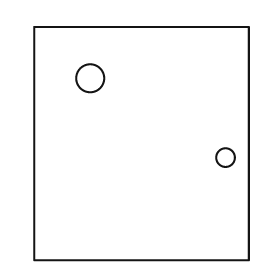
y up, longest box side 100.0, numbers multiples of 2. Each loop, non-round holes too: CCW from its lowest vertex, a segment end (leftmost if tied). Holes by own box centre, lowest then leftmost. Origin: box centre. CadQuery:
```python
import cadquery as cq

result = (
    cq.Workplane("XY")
    .moveTo(-46.0, -50.0)
    .lineTo(46.0, -50.0)
    .lineTo(46.0, 50.0)
    .lineTo(-46.0, 50.0)
    .close()
    .moveTo(36.0, -6.0)
    .circle(4.0)
    .moveTo(-22.0, 28.0)
    .circle(6.0)
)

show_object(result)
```